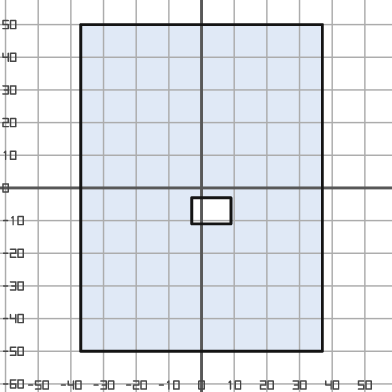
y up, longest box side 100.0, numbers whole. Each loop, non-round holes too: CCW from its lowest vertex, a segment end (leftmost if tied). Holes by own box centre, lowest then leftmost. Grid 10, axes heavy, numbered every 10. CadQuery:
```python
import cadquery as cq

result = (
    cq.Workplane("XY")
    .moveTo(-37.0, -50.0)
    .lineTo(37.0, -50.0)
    .lineTo(37.0, 50.0)
    .lineTo(-37.0, 50.0)
    .close()
    .moveTo(-3.0, -11.0)
    .lineTo(9.0, -11.0)
    .lineTo(9.0, -3.0)
    .lineTo(-3.0, -3.0)
    .close()
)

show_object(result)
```